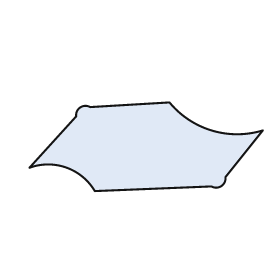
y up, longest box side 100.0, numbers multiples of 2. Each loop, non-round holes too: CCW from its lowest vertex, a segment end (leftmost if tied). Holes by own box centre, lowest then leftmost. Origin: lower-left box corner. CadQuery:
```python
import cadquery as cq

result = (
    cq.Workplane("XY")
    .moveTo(28.0, 0.0)
    .lineTo(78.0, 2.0)
    .threePointArc((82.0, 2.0), (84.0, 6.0))
    .lineTo(100.0, 26.0)
    .threePointArc((78.0, 26.0), (60.0, 38.0))
    .lineTo(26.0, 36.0)
    .threePointArc((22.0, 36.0), (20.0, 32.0))
    .lineTo(0.0, 10.0)
    .threePointArc((16.0, 10.0), (28.0, 0.0))
    .close()
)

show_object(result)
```